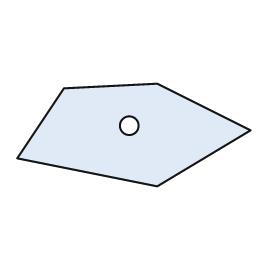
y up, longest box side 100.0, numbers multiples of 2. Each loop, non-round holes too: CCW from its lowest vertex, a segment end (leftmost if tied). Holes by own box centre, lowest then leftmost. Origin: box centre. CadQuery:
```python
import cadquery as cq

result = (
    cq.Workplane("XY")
    .moveTo(10.0, -22.0)
    .lineTo(50.0, 2.0)
    .lineTo(10.0, 22.0)
    .lineTo(-30.0, 20.0)
    .lineTo(-50.0, -10.0)
    .close()
    .moveTo(-2.0, 4.0)
    .circle(4.0)
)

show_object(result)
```